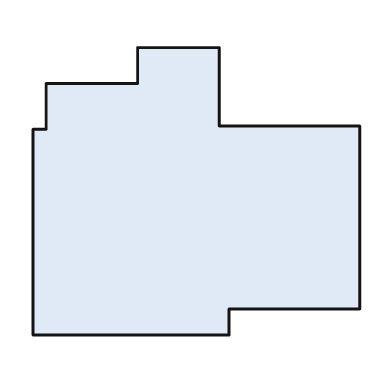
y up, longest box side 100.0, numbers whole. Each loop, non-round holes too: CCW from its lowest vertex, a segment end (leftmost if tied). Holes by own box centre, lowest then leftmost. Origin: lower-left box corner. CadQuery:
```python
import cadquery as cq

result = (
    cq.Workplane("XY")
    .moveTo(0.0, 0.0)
    .lineTo(60.0, 0.0)
    .lineTo(60.0, 8.0)
    .lineTo(100.0, 8.0)
    .lineTo(100.0, 64.0)
    .lineTo(57.0, 64.0)
    .lineTo(57.0, 88.0)
    .lineTo(32.0, 88.0)
    .lineTo(32.0, 77.0)
    .lineTo(4.0, 77.0)
    .lineTo(4.0, 63.0)
    .lineTo(0.0, 63.0)
    .close()
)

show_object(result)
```